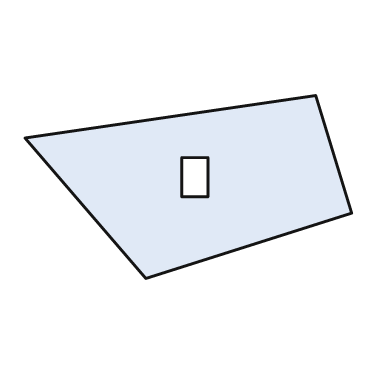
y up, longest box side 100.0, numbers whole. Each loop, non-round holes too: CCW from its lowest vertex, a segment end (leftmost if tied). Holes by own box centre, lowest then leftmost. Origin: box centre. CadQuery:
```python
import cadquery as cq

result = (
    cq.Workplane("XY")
    .moveTo(-13.0, -28.0)
    .lineTo(50.0, -8.0)
    .lineTo(39.0, 28.0)
    .lineTo(-50.0, 15.0)
    .close()
    .moveTo(-2.0, -3.0)
    .lineTo(6.0, -3.0)
    .lineTo(6.0, 9.0)
    .lineTo(-2.0, 9.0)
    .close()
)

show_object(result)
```